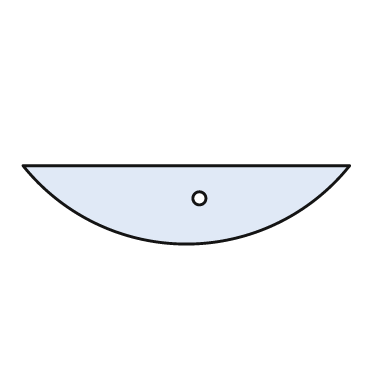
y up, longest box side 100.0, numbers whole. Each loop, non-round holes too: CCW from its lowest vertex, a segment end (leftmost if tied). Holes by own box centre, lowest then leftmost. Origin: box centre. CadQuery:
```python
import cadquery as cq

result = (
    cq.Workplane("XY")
    .moveTo(-50.0, 12.0)
    .threePointArc((0.0, -12.0), (50.0, 12.0))
    .close()
    .moveTo(4.0, 2.0)
    .circle(2.0)
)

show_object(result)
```